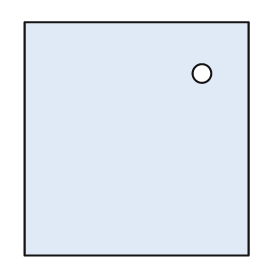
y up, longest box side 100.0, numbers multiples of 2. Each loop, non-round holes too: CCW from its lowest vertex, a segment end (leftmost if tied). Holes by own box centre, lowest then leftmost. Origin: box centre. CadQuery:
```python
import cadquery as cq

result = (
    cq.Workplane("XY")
    .moveTo(-48.0, -50.0)
    .lineTo(48.0, -50.0)
    .lineTo(48.0, 50.0)
    .lineTo(-48.0, 50.0)
    .close()
    .moveTo(28.0, 28.0)
    .circle(4.0)
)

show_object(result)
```